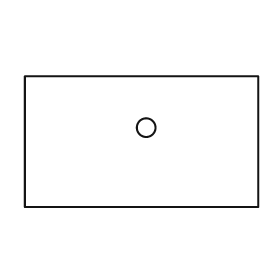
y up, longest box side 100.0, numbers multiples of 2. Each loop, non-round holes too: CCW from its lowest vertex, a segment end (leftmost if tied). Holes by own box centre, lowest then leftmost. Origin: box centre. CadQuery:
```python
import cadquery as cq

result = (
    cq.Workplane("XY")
    .moveTo(-50.0, -28.0)
    .lineTo(50.0, -28.0)
    .lineTo(50.0, 28.0)
    .lineTo(-50.0, 28.0)
    .close()
    .moveTo(2.0, 6.0)
    .circle(4.0)
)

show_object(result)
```